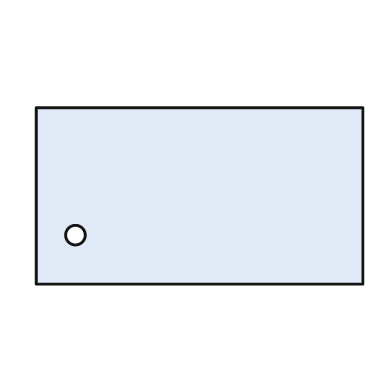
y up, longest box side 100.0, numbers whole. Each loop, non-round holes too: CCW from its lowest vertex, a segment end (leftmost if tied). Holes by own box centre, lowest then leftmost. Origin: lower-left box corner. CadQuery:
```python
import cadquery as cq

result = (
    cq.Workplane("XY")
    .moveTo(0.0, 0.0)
    .lineTo(100.0, 0.0)
    .lineTo(100.0, 54.0)
    .lineTo(0.0, 54.0)
    .close()
    .moveTo(12.0, 15.0)
    .circle(3.0)
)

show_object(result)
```